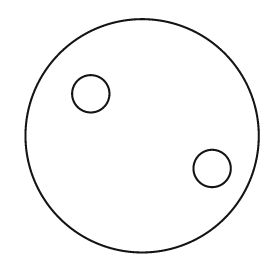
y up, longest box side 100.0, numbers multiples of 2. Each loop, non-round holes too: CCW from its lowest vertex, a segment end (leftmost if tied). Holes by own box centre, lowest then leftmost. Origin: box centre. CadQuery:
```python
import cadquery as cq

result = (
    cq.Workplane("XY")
    .moveTo(0.0, 0.0)
    .circle(50.0)
    .moveTo(30.0, -14.0)
    .circle(8.0)
    .moveTo(-22.0, 18.0)
    .circle(8.0)
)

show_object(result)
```